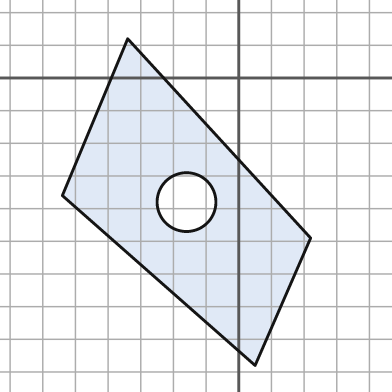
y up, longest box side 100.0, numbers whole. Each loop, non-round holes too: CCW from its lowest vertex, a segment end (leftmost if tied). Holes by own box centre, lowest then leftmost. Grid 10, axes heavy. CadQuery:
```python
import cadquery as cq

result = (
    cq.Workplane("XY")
    .moveTo(5.0, -88.0)
    .lineTo(22.0, -49.0)
    .lineTo(-34.0, 12.0)
    .lineTo(-54.0, -36.0)
    .close()
    .moveTo(-16.0, -38.0)
    .circle(9.0)
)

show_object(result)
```